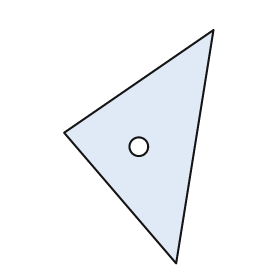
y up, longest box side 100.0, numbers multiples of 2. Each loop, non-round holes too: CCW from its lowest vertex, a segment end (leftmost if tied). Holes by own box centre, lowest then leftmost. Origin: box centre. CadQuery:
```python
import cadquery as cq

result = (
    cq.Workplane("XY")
    .moveTo(16.0, -50.0)
    .lineTo(32.0, 50.0)
    .lineTo(-32.0, 6.0)
    .close()
    .moveTo(0.0, 0.0)
    .circle(4.0)
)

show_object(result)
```